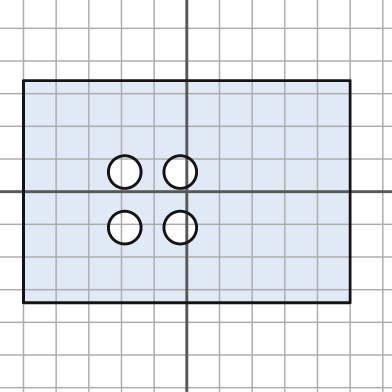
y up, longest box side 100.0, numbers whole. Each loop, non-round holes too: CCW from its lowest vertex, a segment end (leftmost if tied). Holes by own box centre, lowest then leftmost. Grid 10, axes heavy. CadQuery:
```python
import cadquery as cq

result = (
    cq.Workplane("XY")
    .moveTo(-50.0, -34.0)
    .lineTo(50.0, -34.0)
    .lineTo(50.0, 34.0)
    .lineTo(-50.0, 34.0)
    .close()
    .moveTo(-19.0, -11.0)
    .circle(5.0)
    .moveTo(-2.0, -11.0)
    .circle(5.0)
    .moveTo(-19.0, 6.0)
    .circle(5.0)
    .moveTo(-2.0, 6.0)
    .circle(5.0)
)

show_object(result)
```